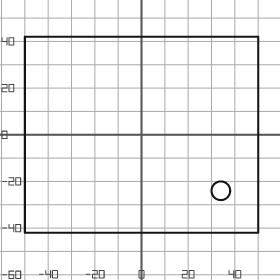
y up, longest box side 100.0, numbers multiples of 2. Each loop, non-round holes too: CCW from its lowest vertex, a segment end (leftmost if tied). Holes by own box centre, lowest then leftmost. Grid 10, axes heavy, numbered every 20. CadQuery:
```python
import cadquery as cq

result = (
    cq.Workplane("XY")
    .moveTo(-50.0, -42.0)
    .lineTo(50.0, -42.0)
    .lineTo(50.0, 42.0)
    .lineTo(-50.0, 42.0)
    .close()
    .moveTo(34.0, -24.0)
    .circle(4.0)
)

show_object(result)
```